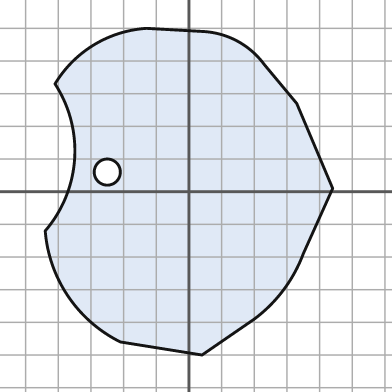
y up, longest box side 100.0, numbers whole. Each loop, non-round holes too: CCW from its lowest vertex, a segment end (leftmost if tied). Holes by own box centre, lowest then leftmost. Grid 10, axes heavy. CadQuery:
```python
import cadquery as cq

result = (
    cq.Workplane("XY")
    .moveTo(4.0, -50.0)
    .lineTo(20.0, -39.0)
    .threePointArc((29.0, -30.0), (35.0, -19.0))
    .lineTo(44.0, 1.0)
    .lineTo(33.0, 27.0)
    .lineTo(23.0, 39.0)
    .threePointArc((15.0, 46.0), (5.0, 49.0))
    .lineTo(-13.0, 50.0)
    .threePointArc((-29.0, 45.0), (-41.0, 33.0))
    .threePointArc((-35.0, 10.0), (-44.0, -12.0))
    .threePointArc((-37.0, -32.0), (-21.0, -46.0))
    .close()
    .moveTo(-25.0, 6.0)
    .circle(4.0)
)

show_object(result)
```